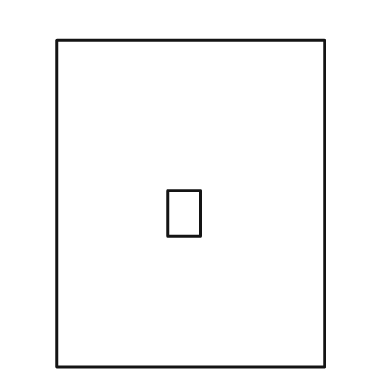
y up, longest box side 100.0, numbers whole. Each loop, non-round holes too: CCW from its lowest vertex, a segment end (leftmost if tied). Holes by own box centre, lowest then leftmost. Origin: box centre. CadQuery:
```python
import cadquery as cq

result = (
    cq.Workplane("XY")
    .moveTo(-41.0, -50.0)
    .lineTo(41.0, -50.0)
    .lineTo(41.0, 50.0)
    .lineTo(-41.0, 50.0)
    .close()
    .moveTo(-7.0, -10.0)
    .lineTo(3.0, -10.0)
    .lineTo(3.0, 4.0)
    .lineTo(-7.0, 4.0)
    .close()
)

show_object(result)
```